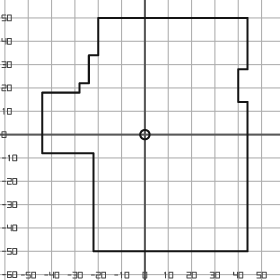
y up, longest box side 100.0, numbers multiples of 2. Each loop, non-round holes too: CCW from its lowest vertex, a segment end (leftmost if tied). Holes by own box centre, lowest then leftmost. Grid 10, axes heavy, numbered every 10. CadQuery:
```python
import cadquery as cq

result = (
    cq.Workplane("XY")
    .moveTo(-22.0, -50.0)
    .lineTo(44.0, -50.0)
    .lineTo(44.0, 14.0)
    .lineTo(40.0, 14.0)
    .lineTo(40.0, 28.0)
    .lineTo(44.0, 28.0)
    .lineTo(44.0, 50.0)
    .lineTo(-20.0, 50.0)
    .lineTo(-20.0, 34.0)
    .lineTo(-24.0, 34.0)
    .lineTo(-24.0, 22.0)
    .lineTo(-28.0, 22.0)
    .lineTo(-28.0, 18.0)
    .lineTo(-44.0, 18.0)
    .lineTo(-44.0, -8.0)
    .lineTo(-22.0, -8.0)
    .close()
    .moveTo(0.0, 0.0)
    .circle(2.0)
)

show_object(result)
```